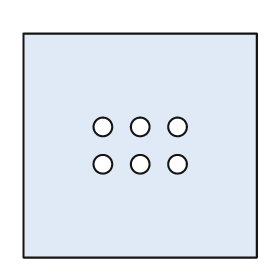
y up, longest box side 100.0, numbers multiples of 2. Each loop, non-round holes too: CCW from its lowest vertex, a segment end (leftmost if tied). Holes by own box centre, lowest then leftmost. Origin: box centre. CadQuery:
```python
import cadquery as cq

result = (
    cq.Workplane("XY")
    .moveTo(-50.0, -48.0)
    .lineTo(50.0, -48.0)
    .lineTo(50.0, 48.0)
    .lineTo(-50.0, 48.0)
    .close()
    .moveTo(-16.0, -8.0)
    .circle(4.0)
    .moveTo(0.0, -8.0)
    .circle(4.0)
    .moveTo(16.0, -8.0)
    .circle(4.0)
    .moveTo(-16.0, 8.0)
    .circle(4.0)
    .moveTo(0.0, 8.0)
    .circle(4.0)
    .moveTo(16.0, 8.0)
    .circle(4.0)
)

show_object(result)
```